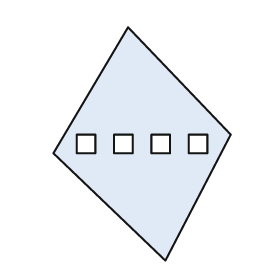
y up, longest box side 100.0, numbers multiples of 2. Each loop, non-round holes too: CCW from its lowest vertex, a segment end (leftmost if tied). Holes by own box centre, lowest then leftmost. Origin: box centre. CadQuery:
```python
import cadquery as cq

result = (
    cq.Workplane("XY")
    .moveTo(10.0, -50.0)
    .lineTo(38.0, 4.0)
    .lineTo(-6.0, 50.0)
    .lineTo(-38.0, -4.0)
    .close()
    .moveTo(-28.0, -4.0)
    .lineTo(-20.0, -4.0)
    .lineTo(-20.0, 4.0)
    .lineTo(-28.0, 4.0)
    .close()
    .moveTo(-12.0, -4.0)
    .lineTo(-4.0, -4.0)
    .lineTo(-4.0, 4.0)
    .lineTo(-12.0, 4.0)
    .close()
    .moveTo(4.0, -4.0)
    .lineTo(12.0, -4.0)
    .lineTo(12.0, 4.0)
    .lineTo(4.0, 4.0)
    .close()
    .moveTo(20.0, -4.0)
    .lineTo(28.0, -4.0)
    .lineTo(28.0, 4.0)
    .lineTo(20.0, 4.0)
    .close()
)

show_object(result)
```